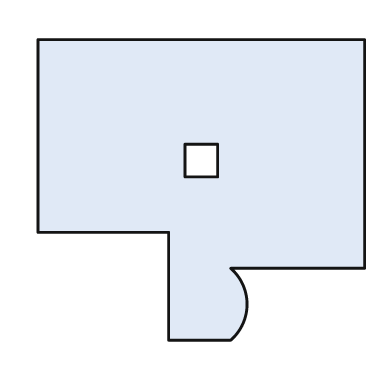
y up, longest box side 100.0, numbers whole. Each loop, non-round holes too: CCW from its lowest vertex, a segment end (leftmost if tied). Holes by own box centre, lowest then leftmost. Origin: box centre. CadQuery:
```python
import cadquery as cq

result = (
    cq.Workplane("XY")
    .moveTo(-10.0, -46.0)
    .lineTo(9.0, -46.0)
    .threePointArc((14.0, -35.0), (9.0, -24.0))
    .lineTo(50.0, -24.0)
    .lineTo(50.0, 46.0)
    .lineTo(-50.0, 46.0)
    .lineTo(-50.0, -13.0)
    .lineTo(-10.0, -13.0)
    .close()
    .moveTo(-5.0, 4.0)
    .lineTo(5.0, 4.0)
    .lineTo(5.0, 14.0)
    .lineTo(-5.0, 14.0)
    .close()
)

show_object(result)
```